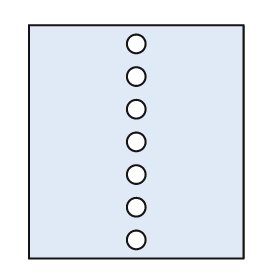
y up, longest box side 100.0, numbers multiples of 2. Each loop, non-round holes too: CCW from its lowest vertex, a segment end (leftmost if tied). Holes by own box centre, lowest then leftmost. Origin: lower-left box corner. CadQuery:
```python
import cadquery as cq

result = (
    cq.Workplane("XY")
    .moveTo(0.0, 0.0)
    .lineTo(92.0, 0.0)
    .lineTo(92.0, 100.0)
    .lineTo(0.0, 100.0)
    .close()
    .moveTo(46.0, 8.0)
    .circle(4.0)
    .moveTo(46.0, 22.0)
    .circle(4.0)
    .moveTo(46.0, 36.0)
    .circle(4.0)
    .moveTo(46.0, 50.0)
    .circle(4.0)
    .moveTo(46.0, 64.0)
    .circle(4.0)
    .moveTo(46.0, 78.0)
    .circle(4.0)
    .moveTo(46.0, 92.0)
    .circle(4.0)
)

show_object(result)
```